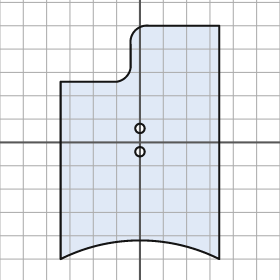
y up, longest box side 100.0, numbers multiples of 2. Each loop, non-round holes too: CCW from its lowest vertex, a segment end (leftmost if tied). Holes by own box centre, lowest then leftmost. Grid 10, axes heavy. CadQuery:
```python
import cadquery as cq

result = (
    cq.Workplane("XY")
    .moveTo(-34.0, -50.0)
    .threePointArc((0.0, -42.0), (34.0, -50.0))
    .lineTo(34.0, 50.0)
    .lineTo(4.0, 50.0)
    .threePointArc((-2.0, 48.0), (-4.0, 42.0))
    .lineTo(-4.0, 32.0)
    .threePointArc((-6.0, 28.0), (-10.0, 26.0))
    .lineTo(-34.0, 26.0)
    .close()
    .moveTo(0.0, -4.0)
    .circle(2.0)
    .moveTo(0.0, 6.0)
    .circle(2.0)
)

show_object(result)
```